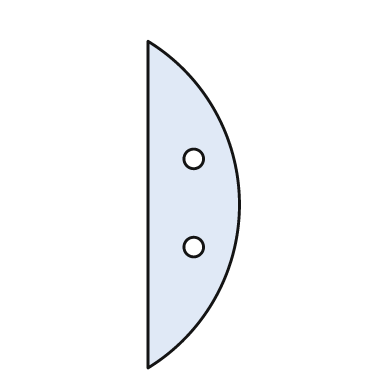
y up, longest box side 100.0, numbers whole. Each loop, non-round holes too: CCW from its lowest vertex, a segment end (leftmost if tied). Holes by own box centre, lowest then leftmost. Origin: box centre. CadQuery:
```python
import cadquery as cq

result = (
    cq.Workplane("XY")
    .moveTo(-14.0, -50.0)
    .threePointArc((14.0, 0.0), (-14.0, 50.0))
    .close()
    .moveTo(0.0, -13.0)
    .circle(3.0)
    .moveTo(0.0, 14.0)
    .circle(3.0)
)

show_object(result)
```